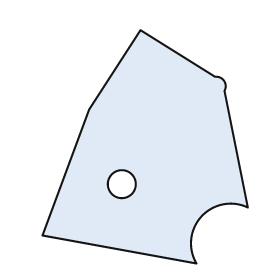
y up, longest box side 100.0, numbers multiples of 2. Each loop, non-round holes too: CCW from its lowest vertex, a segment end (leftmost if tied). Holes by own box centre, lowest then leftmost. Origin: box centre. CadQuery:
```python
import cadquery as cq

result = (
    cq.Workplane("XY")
    .moveTo(22.0, -50.0)
    .threePointArc((24.0, -30.0), (44.0, -26.0))
    .lineTo(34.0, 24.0)
    .threePointArc((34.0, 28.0), (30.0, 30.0))
    .lineTo(-2.0, 50.0)
    .lineTo(-24.0, 16.0)
    .lineTo(-44.0, -38.0)
    .close()
    .moveTo(-10.0, -16.0)
    .circle(6.0)
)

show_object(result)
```